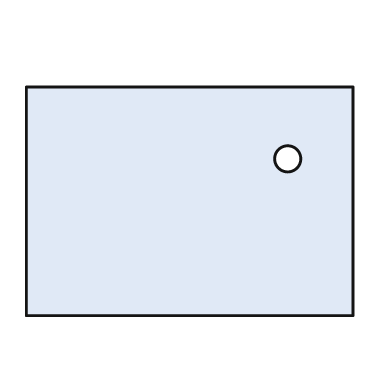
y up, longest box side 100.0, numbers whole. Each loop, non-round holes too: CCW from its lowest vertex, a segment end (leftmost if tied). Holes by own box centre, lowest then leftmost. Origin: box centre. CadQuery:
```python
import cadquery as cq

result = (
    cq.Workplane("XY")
    .moveTo(-50.0, -35.0)
    .lineTo(50.0, -35.0)
    .lineTo(50.0, 35.0)
    .lineTo(-50.0, 35.0)
    .close()
    .moveTo(30.0, 13.0)
    .circle(4.0)
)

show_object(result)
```